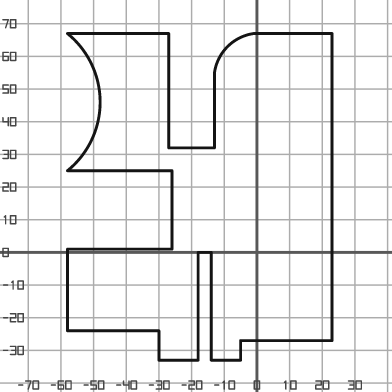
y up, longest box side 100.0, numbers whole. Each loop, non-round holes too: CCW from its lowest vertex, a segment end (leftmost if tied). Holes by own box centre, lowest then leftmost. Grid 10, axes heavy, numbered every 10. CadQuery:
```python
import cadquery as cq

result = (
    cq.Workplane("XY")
    .moveTo(-30.0, -33.0)
    .lineTo(-18.0, -33.0)
    .lineTo(-18.0, 0.0)
    .lineTo(-14.0, 0.0)
    .lineTo(-14.0, -33.0)
    .lineTo(-5.0, -33.0)
    .lineTo(-5.0, -27.0)
    .lineTo(23.0, -27.0)
    .lineTo(23.0, 67.0)
    .lineTo(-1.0, 67.0)
    .threePointArc((-9.0, 63.0), (-13.0, 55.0))
    .lineTo(-13.0, 32.0)
    .lineTo(-27.0, 32.0)
    .lineTo(-27.0, 67.0)
    .lineTo(-58.0, 67.0)
    .threePointArc((-48.0, 46.0), (-58.0, 25.0))
    .lineTo(-26.0, 25.0)
    .lineTo(-26.0, 1.0)
    .lineTo(-58.0, 1.0)
    .lineTo(-58.0, -24.0)
    .lineTo(-30.0, -24.0)
    .close()
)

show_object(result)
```